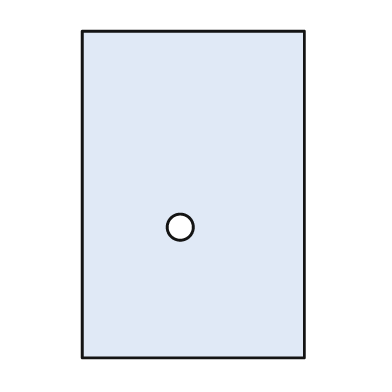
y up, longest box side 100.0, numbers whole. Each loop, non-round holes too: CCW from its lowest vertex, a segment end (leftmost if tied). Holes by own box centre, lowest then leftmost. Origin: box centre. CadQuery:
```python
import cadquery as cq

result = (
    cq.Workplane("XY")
    .moveTo(-34.0, -50.0)
    .lineTo(34.0, -50.0)
    .lineTo(34.0, 50.0)
    .lineTo(-34.0, 50.0)
    .close()
    .moveTo(-4.0, -10.0)
    .circle(4.0)
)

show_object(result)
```